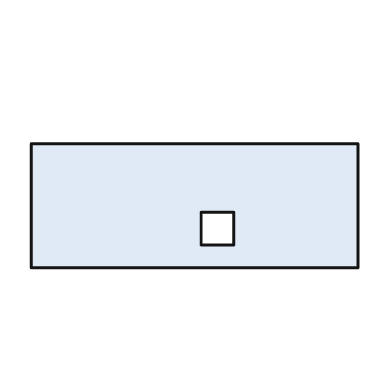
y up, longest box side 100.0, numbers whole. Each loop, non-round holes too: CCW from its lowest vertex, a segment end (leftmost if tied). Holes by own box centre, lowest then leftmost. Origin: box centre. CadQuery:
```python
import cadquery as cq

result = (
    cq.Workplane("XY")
    .moveTo(-50.0, -19.0)
    .lineTo(50.0, -19.0)
    .lineTo(50.0, 19.0)
    .lineTo(-50.0, 19.0)
    .close()
    .moveTo(2.0, -12.0)
    .lineTo(12.0, -12.0)
    .lineTo(12.0, -2.0)
    .lineTo(2.0, -2.0)
    .close()
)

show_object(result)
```